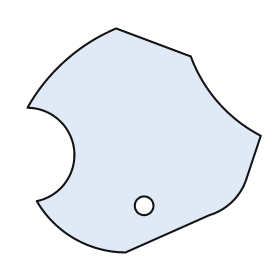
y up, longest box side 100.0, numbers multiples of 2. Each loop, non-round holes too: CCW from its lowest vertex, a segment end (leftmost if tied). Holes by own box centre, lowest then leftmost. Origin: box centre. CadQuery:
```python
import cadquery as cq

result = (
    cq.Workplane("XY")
    .moveTo(-8.0, -48.0)
    .lineTo(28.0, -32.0)
    .threePointArc((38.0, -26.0), (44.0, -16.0))
    .lineTo(50.0, 2.0)
    .threePointArc((32.0, 16.0), (20.0, 36.0))
    .lineTo(-12.0, 48.0)
    .threePointArc((-34.0, 34.0), (-50.0, 14.0))
    .threePointArc((-30.0, -4.0), (-46.0, -26.0))
    .threePointArc((-30.0, -42.0), (-8.0, -48.0))
    .close()
    .moveTo(0.0, -28.0)
    .circle(4.0)
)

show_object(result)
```